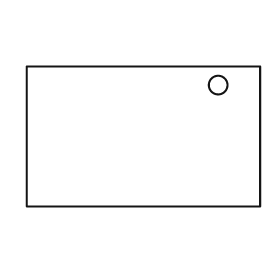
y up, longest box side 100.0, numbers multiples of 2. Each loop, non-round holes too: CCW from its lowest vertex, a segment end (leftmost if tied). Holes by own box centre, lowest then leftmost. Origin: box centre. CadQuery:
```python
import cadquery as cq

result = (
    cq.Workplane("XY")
    .moveTo(-50.0, -30.0)
    .lineTo(50.0, -30.0)
    .lineTo(50.0, 30.0)
    .lineTo(-50.0, 30.0)
    .close()
    .moveTo(32.0, 22.0)
    .circle(4.0)
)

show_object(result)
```